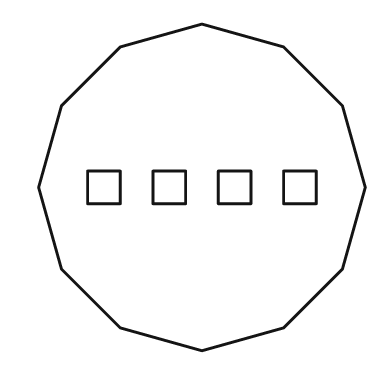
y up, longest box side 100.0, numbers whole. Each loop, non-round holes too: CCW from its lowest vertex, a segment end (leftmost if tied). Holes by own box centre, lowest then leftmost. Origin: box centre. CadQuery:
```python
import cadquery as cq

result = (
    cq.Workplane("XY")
    .moveTo(0.0, -50.0)
    .lineTo(25.0, -43.0)
    .lineTo(43.0, -25.0)
    .lineTo(50.0, 0.0)
    .lineTo(43.0, 25.0)
    .lineTo(25.0, 43.0)
    .lineTo(0.0, 50.0)
    .lineTo(-25.0, 43.0)
    .lineTo(-43.0, 25.0)
    .lineTo(-50.0, 0.0)
    .lineTo(-43.0, -25.0)
    .lineTo(-25.0, -43.0)
    .close()
    .moveTo(-35.0, -5.0)
    .lineTo(-25.0, -5.0)
    .lineTo(-25.0, 5.0)
    .lineTo(-35.0, 5.0)
    .close()
    .moveTo(-15.0, -5.0)
    .lineTo(-5.0, -5.0)
    .lineTo(-5.0, 5.0)
    .lineTo(-15.0, 5.0)
    .close()
    .moveTo(5.0, -5.0)
    .lineTo(15.0, -5.0)
    .lineTo(15.0, 5.0)
    .lineTo(5.0, 5.0)
    .close()
    .moveTo(25.0, -5.0)
    .lineTo(35.0, -5.0)
    .lineTo(35.0, 5.0)
    .lineTo(25.0, 5.0)
    .close()
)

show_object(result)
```